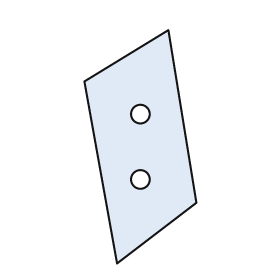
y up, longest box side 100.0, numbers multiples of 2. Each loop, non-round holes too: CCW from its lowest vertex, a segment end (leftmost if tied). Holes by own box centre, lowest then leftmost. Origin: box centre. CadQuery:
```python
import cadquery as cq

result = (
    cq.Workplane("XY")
    .moveTo(-10.0, -50.0)
    .lineTo(24.0, -24.0)
    .lineTo(12.0, 50.0)
    .lineTo(-24.0, 28.0)
    .close()
    .moveTo(0.0, -14.0)
    .circle(4.0)
    .moveTo(0.0, 14.0)
    .circle(4.0)
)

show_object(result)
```